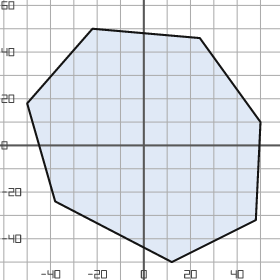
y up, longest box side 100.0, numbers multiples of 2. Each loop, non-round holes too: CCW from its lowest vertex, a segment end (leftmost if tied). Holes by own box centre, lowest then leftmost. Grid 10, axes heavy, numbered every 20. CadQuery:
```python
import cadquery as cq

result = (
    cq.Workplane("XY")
    .moveTo(12.0, -50.0)
    .lineTo(48.0, -32.0)
    .lineTo(50.0, 10.0)
    .lineTo(24.0, 46.0)
    .lineTo(-22.0, 50.0)
    .lineTo(-50.0, 18.0)
    .lineTo(-38.0, -24.0)
    .close()
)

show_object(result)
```